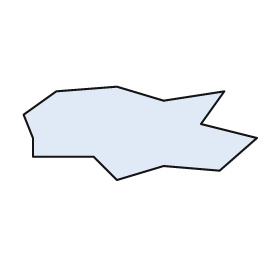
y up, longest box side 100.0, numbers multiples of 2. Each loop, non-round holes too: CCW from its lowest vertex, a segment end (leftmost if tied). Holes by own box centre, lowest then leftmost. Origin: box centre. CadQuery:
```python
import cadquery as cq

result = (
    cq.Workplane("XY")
    .moveTo(-10.0, -20.0)
    .lineTo(10.0, -14.0)
    .lineTo(34.0, -16.0)
    .lineTo(50.0, -2.0)
    .lineTo(26.0, 4.0)
    .lineTo(36.0, 18.0)
    .lineTo(10.0, 14.0)
    .lineTo(-10.0, 20.0)
    .lineTo(-36.0, 18.0)
    .lineTo(-50.0, 8.0)
    .lineTo(-46.0, -2.0)
    .lineTo(-46.0, -10.0)
    .lineTo(-20.0, -10.0)
    .close()
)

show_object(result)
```